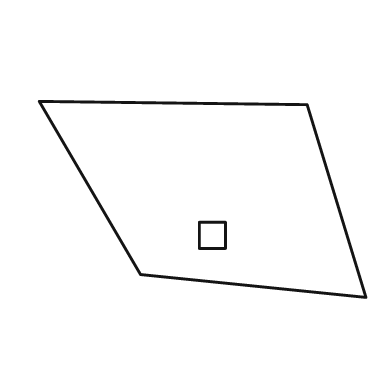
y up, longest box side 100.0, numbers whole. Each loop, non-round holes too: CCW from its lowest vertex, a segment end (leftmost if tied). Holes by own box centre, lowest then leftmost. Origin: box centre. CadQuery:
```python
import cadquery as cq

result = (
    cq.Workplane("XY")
    .moveTo(50.0, -30.0)
    .lineTo(32.0, 29.0)
    .lineTo(-50.0, 30.0)
    .lineTo(-19.0, -23.0)
    .close()
    .moveTo(-1.0, -15.0)
    .lineTo(7.0, -15.0)
    .lineTo(7.0, -7.0)
    .lineTo(-1.0, -7.0)
    .close()
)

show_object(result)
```